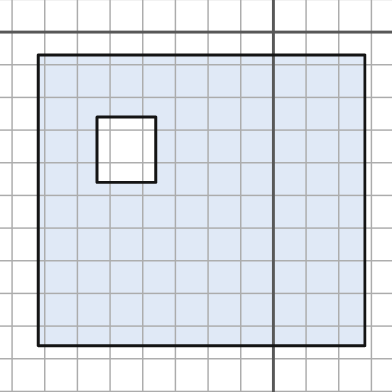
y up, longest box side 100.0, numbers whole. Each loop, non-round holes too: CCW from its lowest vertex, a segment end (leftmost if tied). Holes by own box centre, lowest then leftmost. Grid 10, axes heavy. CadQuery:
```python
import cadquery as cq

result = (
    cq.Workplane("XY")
    .moveTo(-72.0, -96.0)
    .lineTo(28.0, -96.0)
    .lineTo(28.0, -7.0)
    .lineTo(-72.0, -7.0)
    .close()
    .moveTo(-54.0, -46.0)
    .lineTo(-36.0, -46.0)
    .lineTo(-36.0, -26.0)
    .lineTo(-54.0, -26.0)
    .close()
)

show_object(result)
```